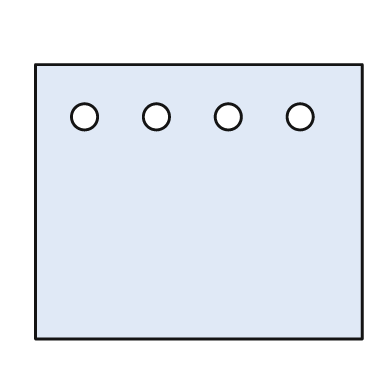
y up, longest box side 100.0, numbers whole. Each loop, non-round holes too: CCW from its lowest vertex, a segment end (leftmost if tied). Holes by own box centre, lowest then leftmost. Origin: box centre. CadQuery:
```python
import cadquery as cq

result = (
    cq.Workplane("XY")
    .moveTo(-50.0, -42.0)
    .lineTo(50.0, -42.0)
    .lineTo(50.0, 42.0)
    .lineTo(-50.0, 42.0)
    .close()
    .moveTo(-35.0, 26.0)
    .circle(4.0)
    .moveTo(-13.0, 26.0)
    .circle(4.0)
    .moveTo(9.0, 26.0)
    .circle(4.0)
    .moveTo(31.0, 26.0)
    .circle(4.0)
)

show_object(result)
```